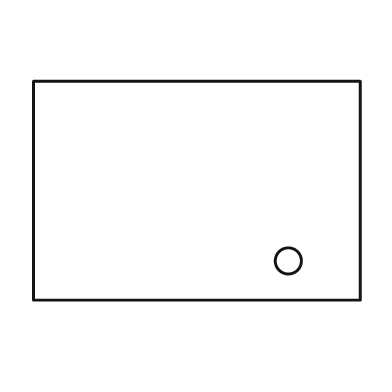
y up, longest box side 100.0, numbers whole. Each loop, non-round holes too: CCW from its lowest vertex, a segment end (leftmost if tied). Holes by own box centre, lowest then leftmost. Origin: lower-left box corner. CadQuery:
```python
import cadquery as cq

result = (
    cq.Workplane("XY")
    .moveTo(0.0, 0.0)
    .lineTo(100.0, 0.0)
    .lineTo(100.0, 67.0)
    .lineTo(0.0, 67.0)
    .close()
    .moveTo(78.0, 12.0)
    .circle(4.0)
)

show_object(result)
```